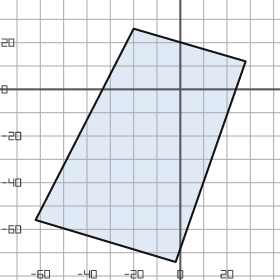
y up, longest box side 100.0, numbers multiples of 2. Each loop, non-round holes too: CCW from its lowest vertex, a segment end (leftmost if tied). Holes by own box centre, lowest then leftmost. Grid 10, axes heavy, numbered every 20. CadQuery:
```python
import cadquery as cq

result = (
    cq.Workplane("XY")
    .moveTo(-2.0, -74.0)
    .lineTo(28.0, 12.0)
    .lineTo(-20.0, 26.0)
    .lineTo(-62.0, -56.0)
    .close()
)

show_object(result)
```